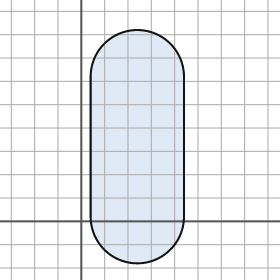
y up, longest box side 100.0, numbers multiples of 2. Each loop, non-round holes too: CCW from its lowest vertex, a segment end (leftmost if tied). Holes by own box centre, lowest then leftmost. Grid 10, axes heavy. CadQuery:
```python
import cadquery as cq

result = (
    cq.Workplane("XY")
    .moveTo(4.0, 2.0)
    .threePointArc((24.0, -18.0), (44.0, 2.0))
    .lineTo(44.0, 62.0)
    .threePointArc((24.0, 82.0), (4.0, 62.0))
    .close()
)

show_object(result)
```